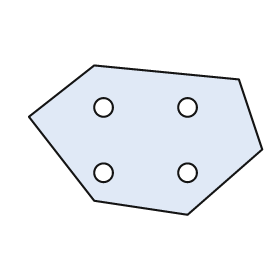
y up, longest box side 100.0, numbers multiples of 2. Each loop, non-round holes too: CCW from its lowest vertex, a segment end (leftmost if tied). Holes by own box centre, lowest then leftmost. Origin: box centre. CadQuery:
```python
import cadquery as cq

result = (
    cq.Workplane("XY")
    .moveTo(18.0, -32.0)
    .lineTo(50.0, -4.0)
    .lineTo(40.0, 26.0)
    .lineTo(-22.0, 32.0)
    .lineTo(-50.0, 10.0)
    .lineTo(-22.0, -26.0)
    .close()
    .moveTo(-18.0, -14.0)
    .circle(4.0)
    .moveTo(18.0, -14.0)
    .circle(4.0)
    .moveTo(-18.0, 14.0)
    .circle(4.0)
    .moveTo(18.0, 14.0)
    .circle(4.0)
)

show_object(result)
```